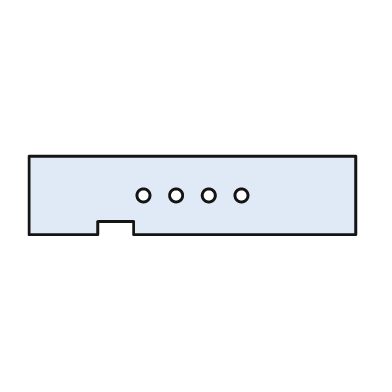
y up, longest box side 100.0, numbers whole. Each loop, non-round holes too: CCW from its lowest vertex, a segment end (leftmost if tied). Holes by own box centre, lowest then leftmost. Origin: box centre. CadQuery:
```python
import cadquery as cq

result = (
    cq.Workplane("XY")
    .moveTo(-50.0, -12.0)
    .lineTo(-29.0, -12.0)
    .lineTo(-29.0, -8.0)
    .lineTo(-18.0, -8.0)
    .lineTo(-18.0, -12.0)
    .lineTo(50.0, -12.0)
    .lineTo(50.0, 12.0)
    .lineTo(-50.0, 12.0)
    .close()
    .moveTo(-15.0, 0.0)
    .circle(2.0)
    .moveTo(-5.0, 0.0)
    .circle(2.0)
    .moveTo(5.0, 0.0)
    .circle(2.0)
    .moveTo(15.0, 0.0)
    .circle(2.0)
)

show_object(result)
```